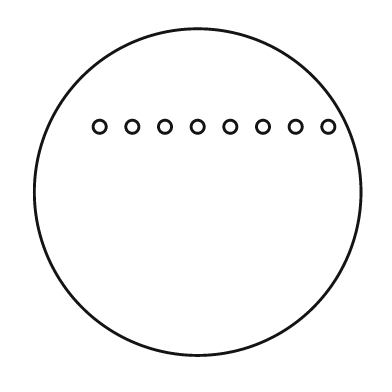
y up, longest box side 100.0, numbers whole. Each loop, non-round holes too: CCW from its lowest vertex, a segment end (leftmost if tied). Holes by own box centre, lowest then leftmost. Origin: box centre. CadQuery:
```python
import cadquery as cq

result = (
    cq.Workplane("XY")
    .moveTo(0.0, 0.0)
    .circle(50.0)
    .moveTo(-30.0, 20.0)
    .circle(2.0)
    .moveTo(-20.0, 20.0)
    .circle(2.0)
    .moveTo(-10.0, 20.0)
    .circle(2.0)
    .moveTo(0.0, 20.0)
    .circle(2.0)
    .moveTo(10.0, 20.0)
    .circle(2.0)
    .moveTo(20.0, 20.0)
    .circle(2.0)
    .moveTo(30.0, 20.0)
    .circle(2.0)
    .moveTo(40.0, 20.0)
    .circle(2.0)
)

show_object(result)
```